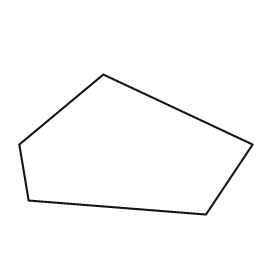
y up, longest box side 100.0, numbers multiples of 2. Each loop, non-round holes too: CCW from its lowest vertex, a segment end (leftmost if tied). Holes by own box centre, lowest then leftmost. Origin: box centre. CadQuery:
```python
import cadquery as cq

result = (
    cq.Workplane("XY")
    .moveTo(30.0, -30.0)
    .lineTo(50.0, 0.0)
    .lineTo(-14.0, 30.0)
    .lineTo(-50.0, 0.0)
    .lineTo(-46.0, -24.0)
    .close()
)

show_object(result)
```